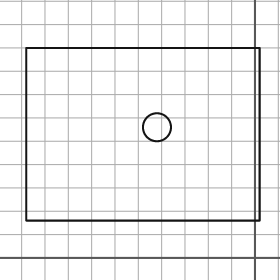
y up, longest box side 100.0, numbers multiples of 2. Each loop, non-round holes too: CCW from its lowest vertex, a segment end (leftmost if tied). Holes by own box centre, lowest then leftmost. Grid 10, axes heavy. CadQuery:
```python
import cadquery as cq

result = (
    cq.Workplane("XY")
    .moveTo(-98.0, 16.0)
    .lineTo(2.0, 16.0)
    .lineTo(2.0, 90.0)
    .lineTo(-98.0, 90.0)
    .close()
    .moveTo(-42.0, 56.0)
    .circle(6.0)
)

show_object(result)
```